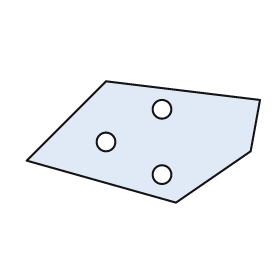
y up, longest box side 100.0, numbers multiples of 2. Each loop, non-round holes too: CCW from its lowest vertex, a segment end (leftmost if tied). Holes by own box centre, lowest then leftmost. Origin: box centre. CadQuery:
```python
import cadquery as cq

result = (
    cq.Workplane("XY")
    .moveTo(14.0, -26.0)
    .lineTo(46.0, -4.0)
    .lineTo(50.0, 18.0)
    .lineTo(-16.0, 26.0)
    .lineTo(-50.0, -8.0)
    .close()
    .moveTo(8.0, -14.0)
    .circle(4.0)
    .moveTo(-16.0, 0.0)
    .circle(4.0)
    .moveTo(8.0, 14.0)
    .circle(4.0)
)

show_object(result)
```